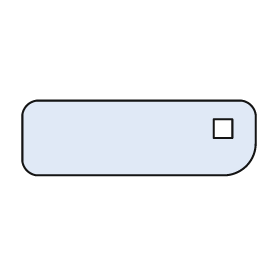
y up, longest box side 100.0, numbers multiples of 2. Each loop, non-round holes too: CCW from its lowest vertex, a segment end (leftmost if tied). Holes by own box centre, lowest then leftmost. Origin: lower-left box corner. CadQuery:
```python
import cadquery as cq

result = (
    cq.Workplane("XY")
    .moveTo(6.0, 0.0)
    .lineTo(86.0, 0.0)
    .threePointArc((96.0, 4.0), (100.0, 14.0))
    .lineTo(100.0, 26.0)
    .threePointArc((98.0, 30.0), (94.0, 32.0))
    .lineTo(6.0, 32.0)
    .threePointArc((2.0, 30.0), (0.0, 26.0))
    .lineTo(0.0, 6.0)
    .threePointArc((2.0, 2.0), (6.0, 0.0))
    .close()
    .moveTo(82.0, 16.0)
    .lineTo(90.0, 16.0)
    .lineTo(90.0, 24.0)
    .lineTo(82.0, 24.0)
    .close()
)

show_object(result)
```